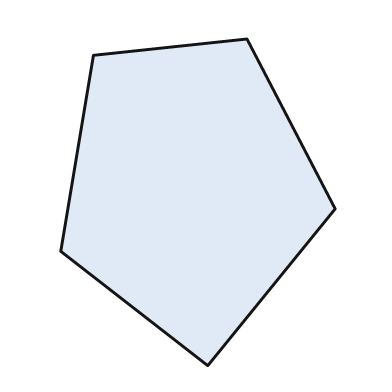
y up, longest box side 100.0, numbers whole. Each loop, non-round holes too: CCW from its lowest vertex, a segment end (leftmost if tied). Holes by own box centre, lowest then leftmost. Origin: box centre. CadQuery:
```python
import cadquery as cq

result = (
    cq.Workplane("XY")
    .moveTo(3.0, -50.0)
    .lineTo(42.0, -2.0)
    .lineTo(15.0, 50.0)
    .lineTo(-32.0, 45.0)
    .lineTo(-42.0, -15.0)
    .close()
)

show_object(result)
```